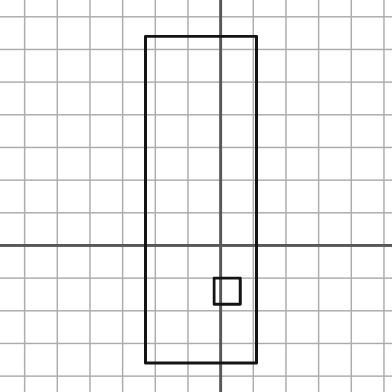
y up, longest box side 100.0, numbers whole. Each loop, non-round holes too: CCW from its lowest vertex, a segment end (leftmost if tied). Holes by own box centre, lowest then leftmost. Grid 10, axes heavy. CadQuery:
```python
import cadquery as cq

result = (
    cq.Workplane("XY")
    .moveTo(-23.0, -36.0)
    .lineTo(11.0, -36.0)
    .lineTo(11.0, 64.0)
    .lineTo(-23.0, 64.0)
    .close()
    .moveTo(-2.0, -18.0)
    .lineTo(6.0, -18.0)
    .lineTo(6.0, -10.0)
    .lineTo(-2.0, -10.0)
    .close()
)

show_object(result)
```